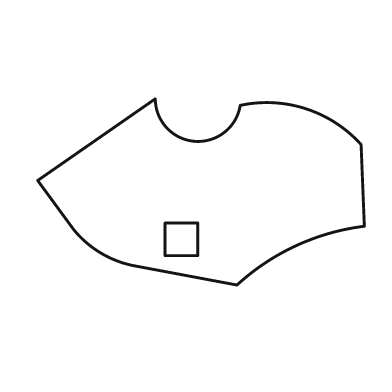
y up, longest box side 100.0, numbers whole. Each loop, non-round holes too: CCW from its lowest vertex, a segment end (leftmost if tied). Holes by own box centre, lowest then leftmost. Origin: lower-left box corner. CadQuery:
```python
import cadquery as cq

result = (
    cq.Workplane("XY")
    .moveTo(61.0, 0.0)
    .threePointArc((79.0, 12.0), (100.0, 18.0))
    .lineTo(99.0, 43.0)
    .threePointArc((82.0, 54.0), (62.0, 55.0))
    .threePointArc((48.0, 44.0), (36.0, 57.0))
    .lineTo(0.0, 32.0)
    .lineTo(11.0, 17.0)
    .threePointArc((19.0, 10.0), (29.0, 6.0))
    .close()
    .moveTo(39.0, 9.0)
    .lineTo(49.0, 9.0)
    .lineTo(49.0, 19.0)
    .lineTo(39.0, 19.0)
    .close()
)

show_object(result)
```